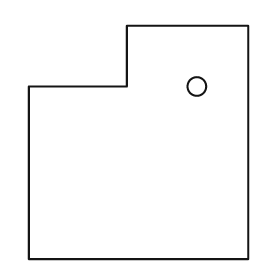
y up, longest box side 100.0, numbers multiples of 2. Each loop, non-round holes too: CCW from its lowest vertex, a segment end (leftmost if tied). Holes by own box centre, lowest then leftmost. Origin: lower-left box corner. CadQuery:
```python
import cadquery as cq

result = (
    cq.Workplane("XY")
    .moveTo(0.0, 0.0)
    .lineTo(94.0, 0.0)
    .lineTo(94.0, 100.0)
    .lineTo(42.0, 100.0)
    .lineTo(42.0, 74.0)
    .lineTo(0.0, 74.0)
    .close()
    .moveTo(72.0, 74.0)
    .circle(4.0)
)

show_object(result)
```